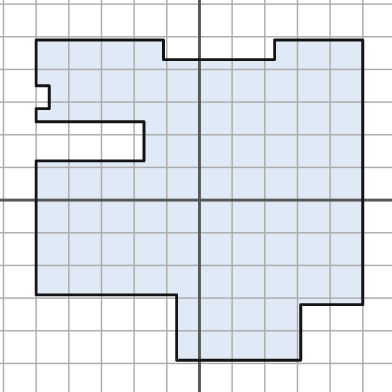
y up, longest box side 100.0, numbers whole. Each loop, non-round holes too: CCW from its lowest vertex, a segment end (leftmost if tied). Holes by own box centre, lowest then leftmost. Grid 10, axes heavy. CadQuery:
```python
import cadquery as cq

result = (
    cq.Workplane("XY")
    .moveTo(-7.0, -49.0)
    .lineTo(31.0, -49.0)
    .lineTo(31.0, -32.0)
    .lineTo(50.0, -32.0)
    .lineTo(50.0, 49.0)
    .lineTo(23.0, 49.0)
    .lineTo(23.0, 43.0)
    .lineTo(-11.0, 43.0)
    .lineTo(-11.0, 49.0)
    .lineTo(-50.0, 49.0)
    .lineTo(-50.0, 35.0)
    .lineTo(-46.0, 35.0)
    .lineTo(-46.0, 28.0)
    .lineTo(-50.0, 28.0)
    .lineTo(-50.0, 24.0)
    .lineTo(-17.0, 24.0)
    .lineTo(-17.0, 12.0)
    .lineTo(-50.0, 12.0)
    .lineTo(-50.0, -29.0)
    .lineTo(-7.0, -29.0)
    .close()
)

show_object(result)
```